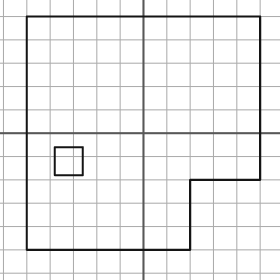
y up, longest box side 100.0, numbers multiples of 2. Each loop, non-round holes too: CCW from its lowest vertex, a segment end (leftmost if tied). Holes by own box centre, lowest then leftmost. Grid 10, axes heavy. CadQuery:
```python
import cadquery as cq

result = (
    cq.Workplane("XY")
    .moveTo(-50.0, -50.0)
    .lineTo(20.0, -50.0)
    .lineTo(20.0, -20.0)
    .lineTo(50.0, -20.0)
    .lineTo(50.0, 50.0)
    .lineTo(-50.0, 50.0)
    .close()
    .moveTo(-38.0, -18.0)
    .lineTo(-26.0, -18.0)
    .lineTo(-26.0, -6.0)
    .lineTo(-38.0, -6.0)
    .close()
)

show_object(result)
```